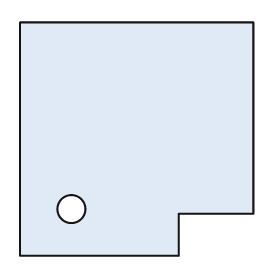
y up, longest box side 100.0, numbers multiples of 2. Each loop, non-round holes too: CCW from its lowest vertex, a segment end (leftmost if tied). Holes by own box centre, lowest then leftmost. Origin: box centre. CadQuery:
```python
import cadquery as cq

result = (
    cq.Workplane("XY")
    .moveTo(-50.0, -50.0)
    .lineTo(18.0, -50.0)
    .lineTo(18.0, -32.0)
    .lineTo(50.0, -32.0)
    .lineTo(50.0, 50.0)
    .lineTo(-50.0, 50.0)
    .close()
    .moveTo(-28.0, -30.0)
    .circle(6.0)
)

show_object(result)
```